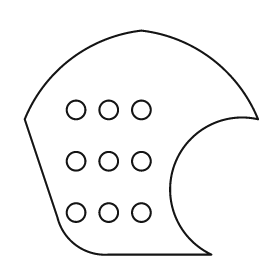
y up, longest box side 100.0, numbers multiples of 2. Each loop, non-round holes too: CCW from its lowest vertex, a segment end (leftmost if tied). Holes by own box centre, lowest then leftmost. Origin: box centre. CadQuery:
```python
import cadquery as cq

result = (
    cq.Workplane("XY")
    .moveTo(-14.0, -48.0)
    .lineTo(30.0, -48.0)
    .threePointArc((14.0, -10.0), (50.0, 10.0))
    .threePointArc((30.0, 36.0), (0.0, 48.0))
    .threePointArc((-30.0, 36.0), (-50.0, 10.0))
    .lineTo(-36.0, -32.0)
    .threePointArc((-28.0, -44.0), (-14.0, -48.0))
    .close()
    .moveTo(-28.0, -30.0)
    .circle(4.0)
    .moveTo(-14.0, -30.0)
    .circle(4.0)
    .moveTo(0.0, -30.0)
    .circle(4.0)
    .moveTo(-28.0, -8.0)
    .circle(4.0)
    .moveTo(-14.0, -8.0)
    .circle(4.0)
    .moveTo(0.0, -8.0)
    .circle(4.0)
    .moveTo(-28.0, 14.0)
    .circle(4.0)
    .moveTo(-14.0, 14.0)
    .circle(4.0)
    .moveTo(0.0, 14.0)
    .circle(4.0)
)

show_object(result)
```